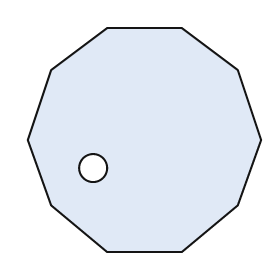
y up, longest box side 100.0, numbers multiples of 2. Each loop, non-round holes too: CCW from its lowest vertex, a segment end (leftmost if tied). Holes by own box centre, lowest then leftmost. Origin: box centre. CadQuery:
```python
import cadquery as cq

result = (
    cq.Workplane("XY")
    .moveTo(-16.0, -48.0)
    .lineTo(16.0, -48.0)
    .lineTo(40.0, -28.0)
    .lineTo(50.0, 0.0)
    .lineTo(40.0, 30.0)
    .lineTo(16.0, 48.0)
    .lineTo(-16.0, 48.0)
    .lineTo(-40.0, 30.0)
    .lineTo(-50.0, 0.0)
    .lineTo(-40.0, -28.0)
    .close()
    .moveTo(-22.0, -12.0)
    .circle(6.0)
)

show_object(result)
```